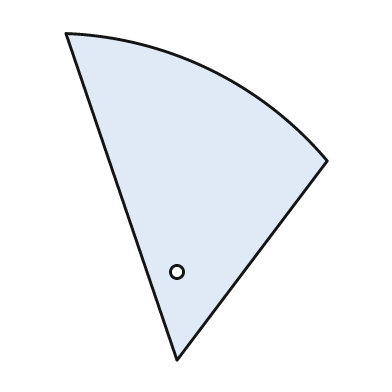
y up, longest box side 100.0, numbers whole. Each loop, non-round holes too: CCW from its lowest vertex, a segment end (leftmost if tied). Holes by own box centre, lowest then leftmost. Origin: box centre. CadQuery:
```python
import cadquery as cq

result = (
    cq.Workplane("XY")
    .moveTo(-6.0, -50.0)
    .lineTo(40.0, 11.0)
    .threePointArc((4.0, 39.0), (-40.0, 50.0))
    .close()
    .moveTo(-6.0, -23.0)
    .circle(2.0)
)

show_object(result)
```